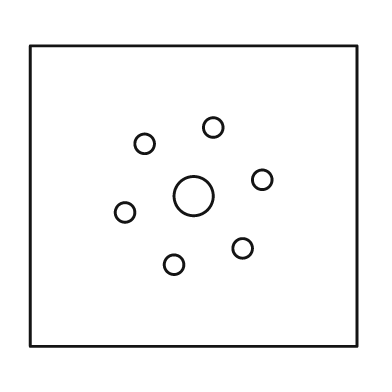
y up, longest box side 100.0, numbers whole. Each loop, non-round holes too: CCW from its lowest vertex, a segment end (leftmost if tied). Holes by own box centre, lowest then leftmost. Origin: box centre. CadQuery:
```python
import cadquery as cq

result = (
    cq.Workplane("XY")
    .moveTo(-50.0, -46.0)
    .lineTo(50.0, -46.0)
    .lineTo(50.0, 46.0)
    .lineTo(-50.0, 46.0)
    .close()
    .moveTo(-6.0, -21.0)
    .circle(3.0)
    .moveTo(15.0, -16.0)
    .circle(3.0)
    .moveTo(-21.0, -5.0)
    .circle(3.0)
    .moveTo(0.0, 0.0)
    .circle(6.0)
    .moveTo(21.0, 5.0)
    .circle(3.0)
    .moveTo(-15.0, 16.0)
    .circle(3.0)
    .moveTo(6.0, 21.0)
    .circle(3.0)
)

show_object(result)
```